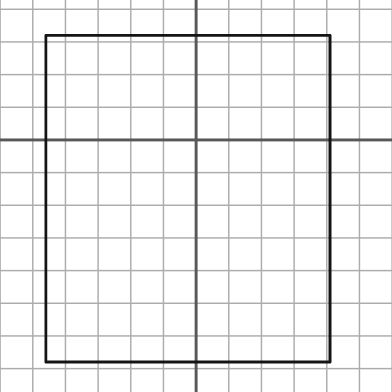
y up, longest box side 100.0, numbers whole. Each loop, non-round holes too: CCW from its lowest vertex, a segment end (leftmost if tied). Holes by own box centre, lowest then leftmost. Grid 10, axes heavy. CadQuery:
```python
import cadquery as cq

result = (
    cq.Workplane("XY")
    .moveTo(-46.0, -68.0)
    .lineTo(41.0, -68.0)
    .lineTo(41.0, 32.0)
    .lineTo(-46.0, 32.0)
    .close()
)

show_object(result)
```